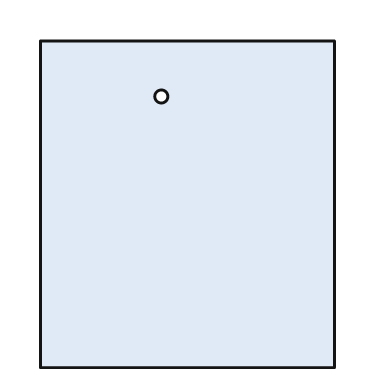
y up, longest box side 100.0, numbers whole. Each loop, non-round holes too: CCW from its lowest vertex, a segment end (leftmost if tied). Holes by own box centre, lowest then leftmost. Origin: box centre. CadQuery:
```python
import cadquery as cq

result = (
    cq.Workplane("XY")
    .moveTo(-45.0, -50.0)
    .lineTo(45.0, -50.0)
    .lineTo(45.0, 50.0)
    .lineTo(-45.0, 50.0)
    .close()
    .moveTo(-8.0, 33.0)
    .circle(2.0)
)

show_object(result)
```